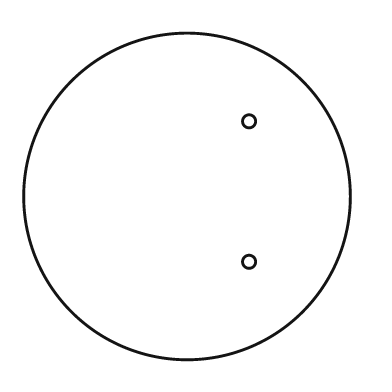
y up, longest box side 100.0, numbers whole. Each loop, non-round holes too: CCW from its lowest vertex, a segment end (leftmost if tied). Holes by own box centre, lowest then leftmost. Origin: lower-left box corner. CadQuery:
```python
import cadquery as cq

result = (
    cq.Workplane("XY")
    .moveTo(50.0, 50.0)
    .circle(50.0)
    .moveTo(69.0, 30.0)
    .circle(2.0)
    .moveTo(69.0, 73.0)
    .circle(2.0)
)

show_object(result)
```